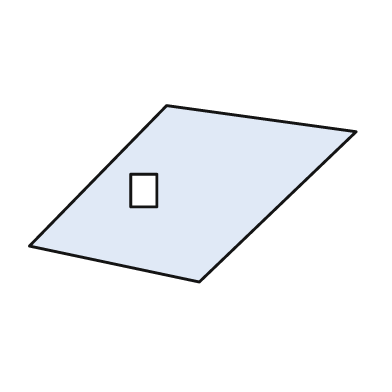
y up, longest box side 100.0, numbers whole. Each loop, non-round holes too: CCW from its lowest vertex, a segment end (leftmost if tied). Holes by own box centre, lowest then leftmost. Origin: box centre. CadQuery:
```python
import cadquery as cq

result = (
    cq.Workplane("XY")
    .moveTo(2.0, -27.0)
    .lineTo(50.0, 19.0)
    .lineTo(-8.0, 27.0)
    .lineTo(-50.0, -16.0)
    .close()
    .moveTo(-19.0, -4.0)
    .lineTo(-11.0, -4.0)
    .lineTo(-11.0, 6.0)
    .lineTo(-19.0, 6.0)
    .close()
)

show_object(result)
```